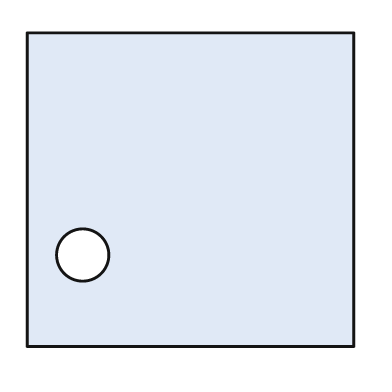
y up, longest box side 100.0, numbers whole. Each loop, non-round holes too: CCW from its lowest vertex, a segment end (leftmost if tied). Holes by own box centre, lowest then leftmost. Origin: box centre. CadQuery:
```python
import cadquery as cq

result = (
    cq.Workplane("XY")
    .moveTo(-50.0, -48.0)
    .lineTo(50.0, -48.0)
    .lineTo(50.0, 48.0)
    .lineTo(-50.0, 48.0)
    .close()
    .moveTo(-33.0, -20.0)
    .circle(8.0)
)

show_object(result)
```